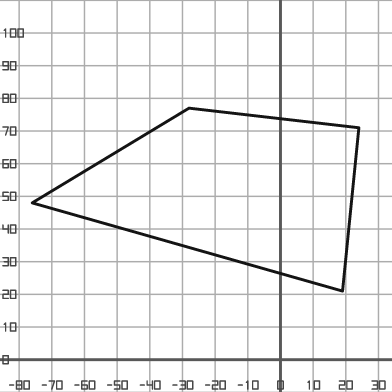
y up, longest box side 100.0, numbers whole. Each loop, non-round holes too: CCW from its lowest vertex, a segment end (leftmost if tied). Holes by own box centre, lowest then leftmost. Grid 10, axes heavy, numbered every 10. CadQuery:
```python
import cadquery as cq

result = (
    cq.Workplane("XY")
    .moveTo(19.0, 21.0)
    .lineTo(24.0, 71.0)
    .lineTo(-28.0, 77.0)
    .lineTo(-76.0, 48.0)
    .close()
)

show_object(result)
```